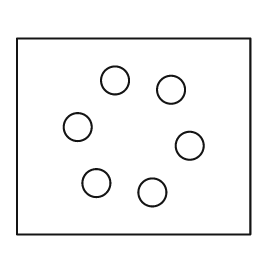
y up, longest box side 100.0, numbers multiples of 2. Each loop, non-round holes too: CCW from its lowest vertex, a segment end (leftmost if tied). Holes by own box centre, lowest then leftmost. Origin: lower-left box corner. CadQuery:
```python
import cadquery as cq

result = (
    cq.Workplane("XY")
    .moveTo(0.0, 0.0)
    .lineTo(100.0, 0.0)
    .lineTo(100.0, 84.0)
    .lineTo(0.0, 84.0)
    .close()
    .moveTo(58.0, 18.0)
    .circle(6.0)
    .moveTo(34.0, 22.0)
    .circle(6.0)
    .moveTo(74.0, 38.0)
    .circle(6.0)
    .moveTo(26.0, 46.0)
    .circle(6.0)
    .moveTo(66.0, 62.0)
    .circle(6.0)
    .moveTo(42.0, 66.0)
    .circle(6.0)
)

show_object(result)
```